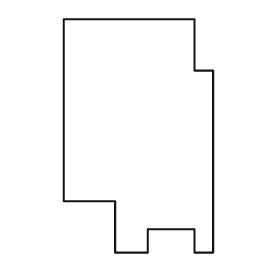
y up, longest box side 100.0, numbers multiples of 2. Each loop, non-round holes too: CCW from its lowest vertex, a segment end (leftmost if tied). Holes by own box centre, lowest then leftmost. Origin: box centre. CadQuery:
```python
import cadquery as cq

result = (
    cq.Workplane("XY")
    .moveTo(-10.0, -50.0)
    .lineTo(4.0, -50.0)
    .lineTo(4.0, -40.0)
    .lineTo(24.0, -40.0)
    .lineTo(24.0, -50.0)
    .lineTo(32.0, -50.0)
    .lineTo(32.0, 28.0)
    .lineTo(24.0, 28.0)
    .lineTo(24.0, 50.0)
    .lineTo(-32.0, 50.0)
    .lineTo(-32.0, -28.0)
    .lineTo(-10.0, -28.0)
    .close()
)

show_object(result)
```